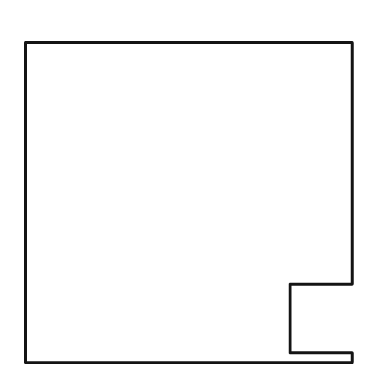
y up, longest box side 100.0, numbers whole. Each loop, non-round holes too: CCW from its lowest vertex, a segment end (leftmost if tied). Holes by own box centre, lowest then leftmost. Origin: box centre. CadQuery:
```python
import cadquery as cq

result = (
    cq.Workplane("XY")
    .moveTo(-50.0, -49.0)
    .lineTo(50.0, -49.0)
    .lineTo(50.0, -46.0)
    .lineTo(31.0, -46.0)
    .lineTo(31.0, -25.0)
    .lineTo(50.0, -25.0)
    .lineTo(50.0, 49.0)
    .lineTo(-50.0, 49.0)
    .close()
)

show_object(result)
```